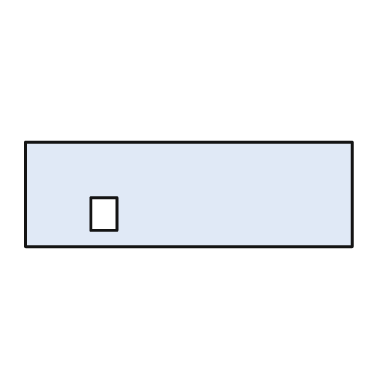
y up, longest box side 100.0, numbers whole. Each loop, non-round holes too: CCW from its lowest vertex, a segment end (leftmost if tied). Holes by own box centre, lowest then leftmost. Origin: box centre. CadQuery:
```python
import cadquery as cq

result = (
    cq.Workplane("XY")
    .moveTo(-50.0, -16.0)
    .lineTo(50.0, -16.0)
    .lineTo(50.0, 16.0)
    .lineTo(-50.0, 16.0)
    .close()
    .moveTo(-30.0, -11.0)
    .lineTo(-22.0, -11.0)
    .lineTo(-22.0, -1.0)
    .lineTo(-30.0, -1.0)
    .close()
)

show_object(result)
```